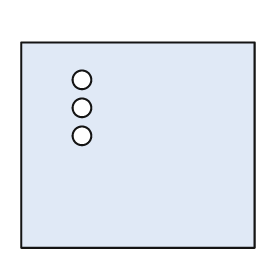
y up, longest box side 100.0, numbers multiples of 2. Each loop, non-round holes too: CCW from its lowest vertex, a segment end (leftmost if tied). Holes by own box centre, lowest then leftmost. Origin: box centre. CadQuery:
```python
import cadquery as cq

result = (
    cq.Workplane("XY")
    .moveTo(-50.0, -44.0)
    .lineTo(50.0, -44.0)
    .lineTo(50.0, 44.0)
    .lineTo(-50.0, 44.0)
    .close()
    .moveTo(-24.0, 4.0)
    .circle(4.0)
    .moveTo(-24.0, 16.0)
    .circle(4.0)
    .moveTo(-24.0, 28.0)
    .circle(4.0)
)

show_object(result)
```